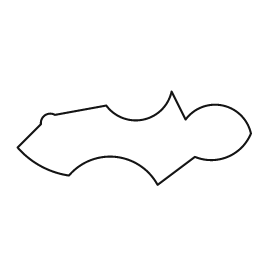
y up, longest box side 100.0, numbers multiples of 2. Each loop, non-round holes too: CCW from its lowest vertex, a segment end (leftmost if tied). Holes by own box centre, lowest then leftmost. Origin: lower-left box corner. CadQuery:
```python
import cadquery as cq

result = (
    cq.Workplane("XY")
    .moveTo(60.0, 0.0)
    .lineTo(76.0, 12.0)
    .threePointArc((90.0, 12.0), (100.0, 22.0))
    .threePointArc((88.0, 34.0), (72.0, 28.0))
    .lineTo(66.0, 40.0)
    .threePointArc((54.0, 28.0), (38.0, 34.0))
    .lineTo(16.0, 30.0)
    .threePointArc((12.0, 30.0), (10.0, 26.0))
    .lineTo(0.0, 16.0)
    .threePointArc((10.0, 8.0), (22.0, 4.0))
    .threePointArc((42.0, 12.0), (60.0, 0.0))
    .close()
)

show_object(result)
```